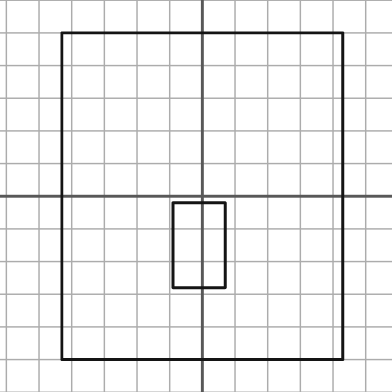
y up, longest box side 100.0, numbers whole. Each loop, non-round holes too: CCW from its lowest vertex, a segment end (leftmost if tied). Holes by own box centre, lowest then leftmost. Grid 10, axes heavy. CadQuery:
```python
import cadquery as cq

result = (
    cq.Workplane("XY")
    .moveTo(-43.0, -50.0)
    .lineTo(43.0, -50.0)
    .lineTo(43.0, 50.0)
    .lineTo(-43.0, 50.0)
    .close()
    .moveTo(-9.0, -28.0)
    .lineTo(7.0, -28.0)
    .lineTo(7.0, -2.0)
    .lineTo(-9.0, -2.0)
    .close()
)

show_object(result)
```